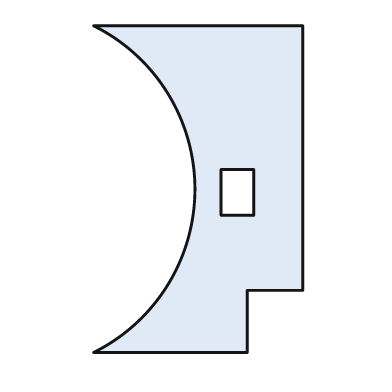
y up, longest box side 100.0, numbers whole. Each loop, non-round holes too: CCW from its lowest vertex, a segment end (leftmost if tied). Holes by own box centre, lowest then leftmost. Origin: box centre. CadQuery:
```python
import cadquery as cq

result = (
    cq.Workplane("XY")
    .moveTo(-32.0, -50.0)
    .lineTo(15.0, -50.0)
    .lineTo(15.0, -31.0)
    .lineTo(32.0, -31.0)
    .lineTo(32.0, 50.0)
    .lineTo(-32.0, 50.0)
    .threePointArc((-1.0, 0.0), (-32.0, -50.0))
    .close()
    .moveTo(7.0, -8.0)
    .lineTo(17.0, -8.0)
    .lineTo(17.0, 6.0)
    .lineTo(7.0, 6.0)
    .close()
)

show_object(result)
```